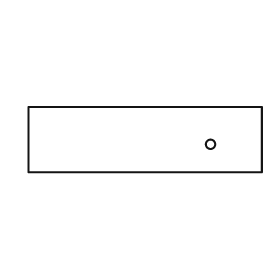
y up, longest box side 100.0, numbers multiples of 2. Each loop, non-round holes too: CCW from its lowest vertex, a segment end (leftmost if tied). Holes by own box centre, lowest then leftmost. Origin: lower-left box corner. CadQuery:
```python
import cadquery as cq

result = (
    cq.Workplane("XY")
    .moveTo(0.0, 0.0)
    .lineTo(100.0, 0.0)
    .lineTo(100.0, 28.0)
    .lineTo(0.0, 28.0)
    .close()
    .moveTo(78.0, 12.0)
    .circle(2.0)
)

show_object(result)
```